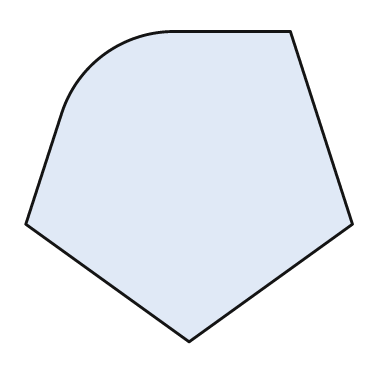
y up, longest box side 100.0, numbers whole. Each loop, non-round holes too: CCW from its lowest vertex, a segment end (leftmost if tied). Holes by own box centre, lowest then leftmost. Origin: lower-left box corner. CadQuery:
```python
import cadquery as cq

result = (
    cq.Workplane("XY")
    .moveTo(50.0, 0.0)
    .lineTo(100.0, 36.0)
    .lineTo(81.0, 95.0)
    .lineTo(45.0, 95.0)
    .threePointArc((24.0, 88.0), (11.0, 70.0))
    .lineTo(0.0, 36.0)
    .close()
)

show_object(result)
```